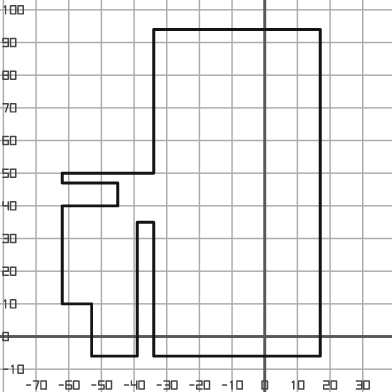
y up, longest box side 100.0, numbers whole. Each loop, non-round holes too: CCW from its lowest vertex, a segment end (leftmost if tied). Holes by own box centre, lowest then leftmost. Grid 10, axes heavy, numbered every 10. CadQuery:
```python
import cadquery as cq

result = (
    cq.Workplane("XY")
    .moveTo(-53.0, -6.0)
    .lineTo(-39.0, -6.0)
    .lineTo(-39.0, 35.0)
    .lineTo(-34.0, 35.0)
    .lineTo(-34.0, -6.0)
    .lineTo(17.0, -6.0)
    .lineTo(17.0, 94.0)
    .lineTo(-34.0, 94.0)
    .lineTo(-34.0, 50.0)
    .lineTo(-62.0, 50.0)
    .lineTo(-62.0, 47.0)
    .lineTo(-45.0, 47.0)
    .lineTo(-45.0, 40.0)
    .lineTo(-62.0, 40.0)
    .lineTo(-62.0, 10.0)
    .lineTo(-53.0, 10.0)
    .close()
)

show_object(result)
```